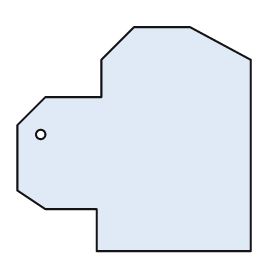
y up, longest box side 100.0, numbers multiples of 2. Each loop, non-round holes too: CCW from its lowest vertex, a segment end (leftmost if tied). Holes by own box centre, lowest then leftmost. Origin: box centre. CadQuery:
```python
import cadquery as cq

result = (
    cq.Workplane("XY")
    .moveTo(-16.0, -48.0)
    .lineTo(50.0, -48.0)
    .lineTo(50.0, 34.0)
    .lineTo(24.0, 48.0)
    .lineTo(0.0, 48.0)
    .lineTo(-14.0, 34.0)
    .lineTo(-14.0, 18.0)
    .lineTo(-38.0, 18.0)
    .lineTo(-50.0, 6.0)
    .lineTo(-50.0, -22.0)
    .lineTo(-38.0, -30.0)
    .lineTo(-16.0, -30.0)
    .close()
    .moveTo(-40.0, 2.0)
    .circle(2.0)
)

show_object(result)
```